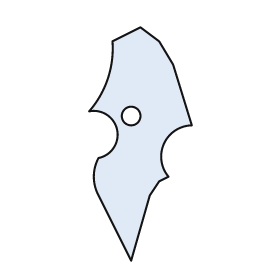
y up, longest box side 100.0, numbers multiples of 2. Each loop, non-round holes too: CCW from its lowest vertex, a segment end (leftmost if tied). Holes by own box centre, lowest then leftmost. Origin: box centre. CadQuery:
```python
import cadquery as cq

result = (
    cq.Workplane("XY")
    .moveTo(-4.0, -50.0)
    .lineTo(4.0, -22.0)
    .lineTo(8.0, -16.0)
    .lineTo(12.0, -14.0)
    .threePointArc((10.0, 0.0), (22.0, 8.0))
    .lineTo(14.0, 34.0)
    .lineTo(8.0, 44.0)
    .lineTo(0.0, 50.0)
    .lineTo(-12.0, 44.0)
    .threePointArc((-14.0, 28.0), (-22.0, 14.0))
    .threePointArc((-10.0, 6.0), (-18.0, -6.0))
    .threePointArc((-20.0, -14.0), (-18.0, -22.0))
    .close()
    .moveTo(-4.0, 12.0)
    .circle(4.0)
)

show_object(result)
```